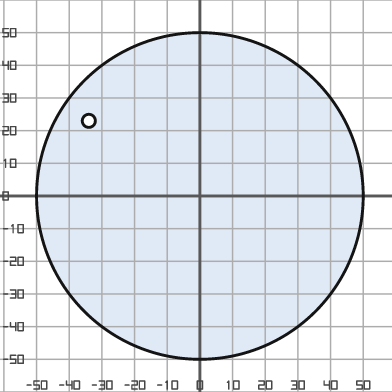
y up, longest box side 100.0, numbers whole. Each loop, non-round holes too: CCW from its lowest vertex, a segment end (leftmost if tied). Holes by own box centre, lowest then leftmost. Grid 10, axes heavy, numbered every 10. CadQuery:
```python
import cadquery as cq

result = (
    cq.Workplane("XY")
    .moveTo(0.0, 0.0)
    .circle(50.0)
    .moveTo(-34.0, 23.0)
    .circle(2.0)
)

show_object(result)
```